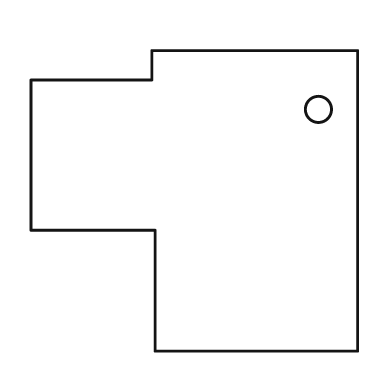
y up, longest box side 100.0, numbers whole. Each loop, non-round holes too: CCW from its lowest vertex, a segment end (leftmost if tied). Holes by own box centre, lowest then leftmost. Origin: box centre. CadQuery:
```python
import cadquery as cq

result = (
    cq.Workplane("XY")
    .moveTo(-12.0, -46.0)
    .lineTo(50.0, -46.0)
    .lineTo(50.0, 46.0)
    .lineTo(-13.0, 46.0)
    .lineTo(-13.0, 37.0)
    .lineTo(-50.0, 37.0)
    .lineTo(-50.0, -9.0)
    .lineTo(-12.0, -9.0)
    .close()
    .moveTo(38.0, 28.0)
    .circle(4.0)
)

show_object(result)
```